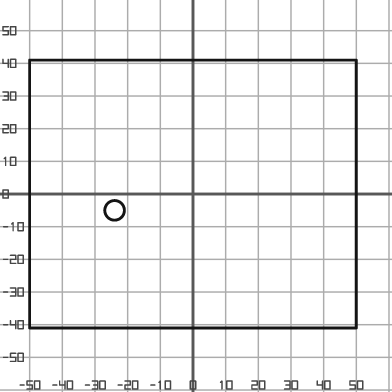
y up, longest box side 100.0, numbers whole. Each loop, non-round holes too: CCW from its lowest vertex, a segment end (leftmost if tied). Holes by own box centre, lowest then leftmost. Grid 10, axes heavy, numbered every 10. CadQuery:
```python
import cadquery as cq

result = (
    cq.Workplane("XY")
    .moveTo(-50.0, -41.0)
    .lineTo(50.0, -41.0)
    .lineTo(50.0, 41.0)
    .lineTo(-50.0, 41.0)
    .close()
    .moveTo(-24.0, -5.0)
    .circle(3.0)
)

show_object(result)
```